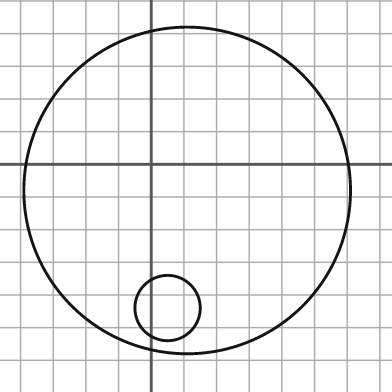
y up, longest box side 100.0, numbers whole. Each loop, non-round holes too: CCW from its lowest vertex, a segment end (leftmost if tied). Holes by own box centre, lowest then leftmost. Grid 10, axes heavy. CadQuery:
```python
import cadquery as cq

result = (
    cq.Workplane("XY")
    .moveTo(11.0, -8.0)
    .circle(50.0)
    .moveTo(5.0, -44.0)
    .circle(10.0)
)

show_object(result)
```